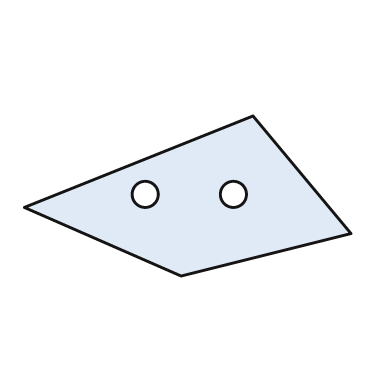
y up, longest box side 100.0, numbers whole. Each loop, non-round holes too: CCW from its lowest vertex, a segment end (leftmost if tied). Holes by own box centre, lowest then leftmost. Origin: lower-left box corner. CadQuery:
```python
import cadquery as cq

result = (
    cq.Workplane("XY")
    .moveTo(48.0, 0.0)
    .lineTo(100.0, 13.0)
    .lineTo(70.0, 49.0)
    .lineTo(0.0, 21.0)
    .close()
    .moveTo(37.0, 25.0)
    .circle(4.0)
    .moveTo(64.0, 25.0)
    .circle(4.0)
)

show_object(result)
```